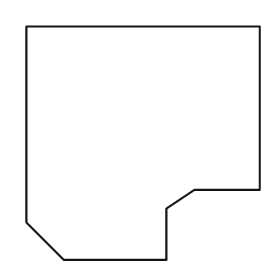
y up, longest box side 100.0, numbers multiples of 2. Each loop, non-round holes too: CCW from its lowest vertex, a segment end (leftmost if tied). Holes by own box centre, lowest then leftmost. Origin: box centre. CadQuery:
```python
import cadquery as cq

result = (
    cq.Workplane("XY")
    .moveTo(-34.0, -50.0)
    .lineTo(10.0, -50.0)
    .lineTo(10.0, -28.0)
    .lineTo(22.0, -20.0)
    .lineTo(50.0, -20.0)
    .lineTo(50.0, 50.0)
    .lineTo(-50.0, 50.0)
    .lineTo(-50.0, -34.0)
    .close()
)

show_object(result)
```